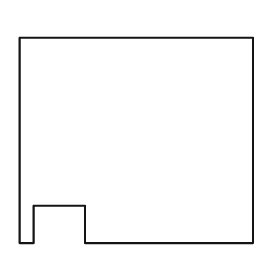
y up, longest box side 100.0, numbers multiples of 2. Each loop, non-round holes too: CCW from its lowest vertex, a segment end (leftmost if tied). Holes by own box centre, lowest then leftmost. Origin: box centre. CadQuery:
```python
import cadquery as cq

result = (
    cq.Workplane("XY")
    .moveTo(-50.0, -44.0)
    .lineTo(-44.0, -44.0)
    .lineTo(-44.0, -28.0)
    .lineTo(-22.0, -28.0)
    .lineTo(-22.0, -44.0)
    .lineTo(50.0, -44.0)
    .lineTo(50.0, 44.0)
    .lineTo(-50.0, 44.0)
    .close()
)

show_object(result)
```